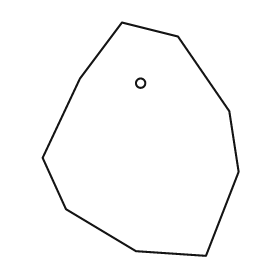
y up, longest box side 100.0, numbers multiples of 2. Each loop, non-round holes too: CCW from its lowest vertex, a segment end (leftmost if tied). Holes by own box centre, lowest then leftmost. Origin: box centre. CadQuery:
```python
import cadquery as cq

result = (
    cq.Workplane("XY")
    .moveTo(28.0, -50.0)
    .lineTo(42.0, -14.0)
    .lineTo(38.0, 12.0)
    .lineTo(16.0, 44.0)
    .lineTo(-8.0, 50.0)
    .lineTo(-26.0, 26.0)
    .lineTo(-42.0, -8.0)
    .lineTo(-32.0, -30.0)
    .lineTo(-2.0, -48.0)
    .close()
    .moveTo(0.0, 24.0)
    .circle(2.0)
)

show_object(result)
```